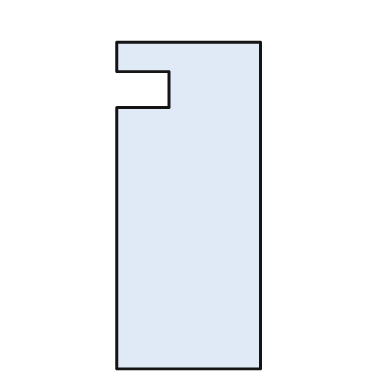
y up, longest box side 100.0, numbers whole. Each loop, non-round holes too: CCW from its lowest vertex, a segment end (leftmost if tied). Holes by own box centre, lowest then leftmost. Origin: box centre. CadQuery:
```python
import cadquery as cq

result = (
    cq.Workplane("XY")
    .moveTo(-22.0, -50.0)
    .lineTo(22.0, -50.0)
    .lineTo(22.0, 50.0)
    .lineTo(-22.0, 50.0)
    .lineTo(-22.0, 41.0)
    .lineTo(-6.0, 41.0)
    .lineTo(-6.0, 30.0)
    .lineTo(-22.0, 30.0)
    .close()
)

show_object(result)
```